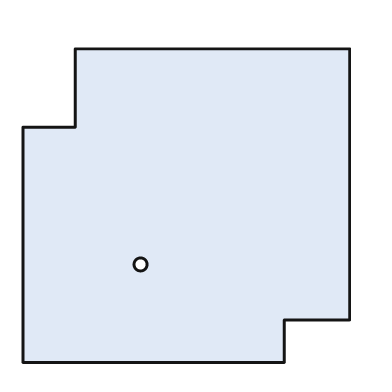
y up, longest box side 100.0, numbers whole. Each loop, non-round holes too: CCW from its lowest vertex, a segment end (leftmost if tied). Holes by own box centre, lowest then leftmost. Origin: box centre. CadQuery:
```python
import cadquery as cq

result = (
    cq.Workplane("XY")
    .moveTo(-50.0, -48.0)
    .lineTo(30.0, -48.0)
    .lineTo(30.0, -35.0)
    .lineTo(50.0, -35.0)
    .lineTo(50.0, 48.0)
    .lineTo(-34.0, 48.0)
    .lineTo(-34.0, 24.0)
    .lineTo(-50.0, 24.0)
    .close()
    .moveTo(-14.0, -18.0)
    .circle(2.0)
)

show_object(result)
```